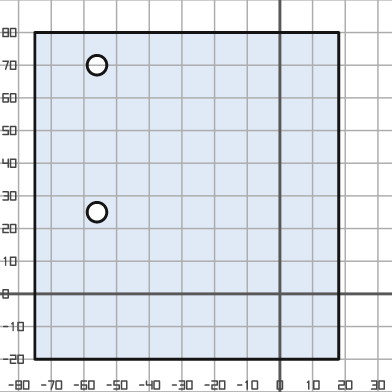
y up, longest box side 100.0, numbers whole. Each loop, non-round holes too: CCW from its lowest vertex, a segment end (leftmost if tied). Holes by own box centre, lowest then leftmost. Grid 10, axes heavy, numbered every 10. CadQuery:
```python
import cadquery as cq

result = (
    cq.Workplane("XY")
    .moveTo(-75.0, -20.0)
    .lineTo(18.0, -20.0)
    .lineTo(18.0, 80.0)
    .lineTo(-75.0, 80.0)
    .close()
    .moveTo(-56.0, 25.0)
    .circle(3.0)
    .moveTo(-56.0, 70.0)
    .circle(3.0)
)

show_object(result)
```